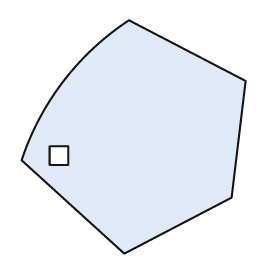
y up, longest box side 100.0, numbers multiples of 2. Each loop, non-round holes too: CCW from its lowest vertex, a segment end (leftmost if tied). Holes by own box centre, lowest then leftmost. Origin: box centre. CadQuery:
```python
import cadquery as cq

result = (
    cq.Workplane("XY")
    .moveTo(-4.0, -50.0)
    .lineTo(42.0, -26.0)
    .lineTo(48.0, 24.0)
    .lineTo(-2.0, 50.0)
    .threePointArc((-30.0, 24.0), (-48.0, -10.0))
    .close()
    .moveTo(-36.0, -12.0)
    .lineTo(-28.0, -12.0)
    .lineTo(-28.0, -4.0)
    .lineTo(-36.0, -4.0)
    .close()
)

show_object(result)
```